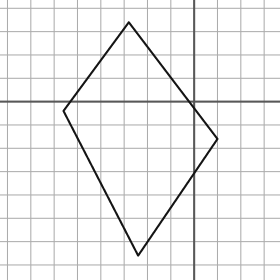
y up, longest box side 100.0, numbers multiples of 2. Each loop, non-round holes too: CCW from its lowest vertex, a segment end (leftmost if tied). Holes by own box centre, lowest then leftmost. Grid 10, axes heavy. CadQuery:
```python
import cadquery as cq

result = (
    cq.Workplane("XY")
    .moveTo(-24.0, -66.0)
    .lineTo(10.0, -16.0)
    .lineTo(-28.0, 34.0)
    .lineTo(-56.0, -4.0)
    .close()
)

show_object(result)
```